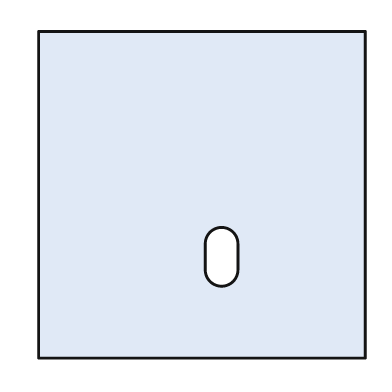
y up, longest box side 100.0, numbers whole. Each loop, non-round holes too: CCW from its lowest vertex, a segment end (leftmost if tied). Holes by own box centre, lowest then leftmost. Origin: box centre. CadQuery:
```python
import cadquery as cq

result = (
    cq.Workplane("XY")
    .moveTo(-50.0, -50.0)
    .lineTo(50.0, -50.0)
    .lineTo(50.0, 50.0)
    .lineTo(-50.0, 50.0)
    .close()
    .moveTo(1.0, -23.0)
    .threePointArc((6.0, -28.0), (11.0, -23.0))
    .lineTo(11.0, -15.0)
    .threePointArc((6.0, -10.0), (1.0, -15.0))
    .close()
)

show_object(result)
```